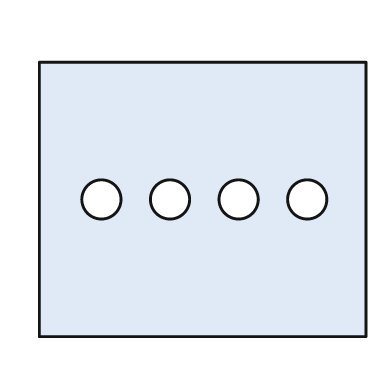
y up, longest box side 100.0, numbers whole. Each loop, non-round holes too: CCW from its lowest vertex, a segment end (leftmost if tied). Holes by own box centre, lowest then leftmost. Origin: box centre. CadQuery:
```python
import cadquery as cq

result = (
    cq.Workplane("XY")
    .moveTo(-50.0, -42.0)
    .lineTo(50.0, -42.0)
    .lineTo(50.0, 42.0)
    .lineTo(-50.0, 42.0)
    .close()
    .moveTo(-31.0, 0.0)
    .circle(6.0)
    .moveTo(-10.0, 0.0)
    .circle(6.0)
    .moveTo(11.0, 0.0)
    .circle(6.0)
    .moveTo(32.0, 0.0)
    .circle(6.0)
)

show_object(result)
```